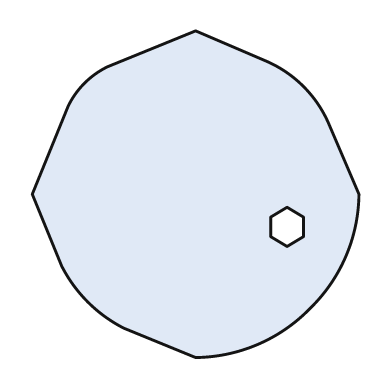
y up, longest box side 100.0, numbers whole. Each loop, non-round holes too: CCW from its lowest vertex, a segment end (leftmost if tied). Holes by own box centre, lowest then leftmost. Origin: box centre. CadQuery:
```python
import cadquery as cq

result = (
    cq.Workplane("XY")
    .moveTo(0.0, -50.0)
    .threePointArc((19.0, -46.0), (35.0, -35.0))
    .threePointArc((46.0, -19.0), (50.0, 0.0))
    .lineTo(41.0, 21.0)
    .threePointArc((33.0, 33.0), (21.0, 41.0))
    .lineTo(0.0, 50.0)
    .lineTo(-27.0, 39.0)
    .threePointArc((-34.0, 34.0), (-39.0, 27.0))
    .lineTo(-50.0, 0.0)
    .lineTo(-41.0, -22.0)
    .threePointArc((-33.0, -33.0), (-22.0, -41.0))
    .close()
    .moveTo(28.0, -16.0)
    .lineTo(33.0, -13.0)
    .lineTo(33.0, -7.0)
    .lineTo(28.0, -4.0)
    .lineTo(23.0, -7.0)
    .lineTo(23.0, -13.0)
    .close()
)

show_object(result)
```